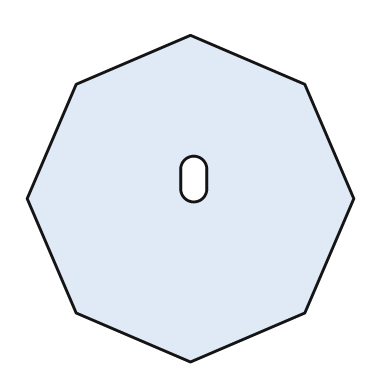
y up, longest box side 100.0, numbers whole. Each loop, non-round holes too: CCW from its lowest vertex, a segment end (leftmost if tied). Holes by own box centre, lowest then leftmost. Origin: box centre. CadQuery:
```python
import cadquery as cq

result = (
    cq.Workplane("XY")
    .moveTo(0.0, -50.0)
    .lineTo(35.0, -35.0)
    .lineTo(50.0, 0.0)
    .lineTo(35.0, 35.0)
    .lineTo(0.0, 50.0)
    .lineTo(-35.0, 35.0)
    .lineTo(-50.0, 0.0)
    .lineTo(-35.0, -35.0)
    .close()
    .moveTo(-3.0, 3.0)
    .threePointArc((1.0, -1.0), (5.0, 3.0))
    .lineTo(5.0, 9.0)
    .threePointArc((1.0, 13.0), (-3.0, 9.0))
    .close()
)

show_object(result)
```